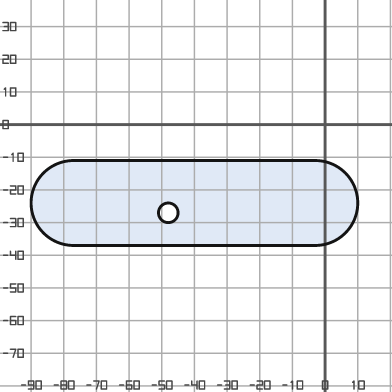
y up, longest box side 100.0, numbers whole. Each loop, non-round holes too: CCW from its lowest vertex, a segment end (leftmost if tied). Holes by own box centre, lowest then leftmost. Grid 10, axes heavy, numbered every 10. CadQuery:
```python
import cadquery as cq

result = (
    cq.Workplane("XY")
    .moveTo(-77.0, -37.0)
    .lineTo(-3.0, -37.0)
    .threePointArc((10.0, -24.0), (-3.0, -11.0))
    .lineTo(-77.0, -11.0)
    .threePointArc((-90.0, -24.0), (-77.0, -37.0))
    .close()
    .moveTo(-48.0, -27.0)
    .circle(3.0)
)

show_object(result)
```